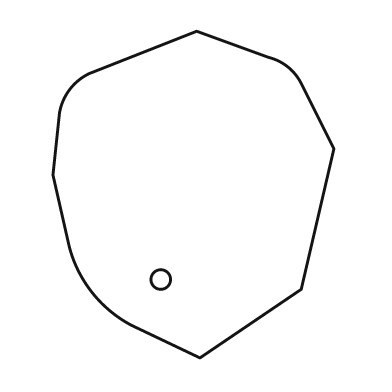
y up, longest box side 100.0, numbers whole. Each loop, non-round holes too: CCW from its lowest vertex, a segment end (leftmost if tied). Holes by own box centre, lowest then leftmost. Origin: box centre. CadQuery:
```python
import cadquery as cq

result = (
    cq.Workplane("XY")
    .moveTo(2.0, -50.0)
    .lineTo(33.0, -29.0)
    .lineTo(43.0, 14.0)
    .lineTo(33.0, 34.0)
    .threePointArc((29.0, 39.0), (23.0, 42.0))
    .lineTo(1.0, 50.0)
    .lineTo(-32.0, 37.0)
    .threePointArc((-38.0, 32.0), (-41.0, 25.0))
    .lineTo(-43.0, 6.0)
    .lineTo(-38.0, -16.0)
    .threePointArc((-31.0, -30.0), (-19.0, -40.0))
    .close()
    .moveTo(-10.0, -26.0)
    .circle(3.0)
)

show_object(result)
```